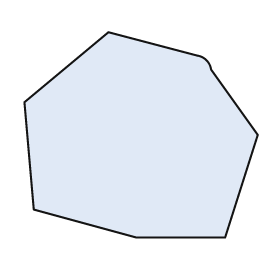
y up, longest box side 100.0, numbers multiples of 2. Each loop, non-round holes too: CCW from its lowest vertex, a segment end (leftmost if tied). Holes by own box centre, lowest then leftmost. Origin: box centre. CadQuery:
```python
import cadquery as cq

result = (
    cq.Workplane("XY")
    .moveTo(-2.0, -44.0)
    .lineTo(36.0, -44.0)
    .lineTo(50.0, 0.0)
    .lineTo(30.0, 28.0)
    .threePointArc((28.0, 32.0), (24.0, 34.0))
    .lineTo(-14.0, 44.0)
    .lineTo(-50.0, 14.0)
    .lineTo(-46.0, -32.0)
    .close()
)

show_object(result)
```